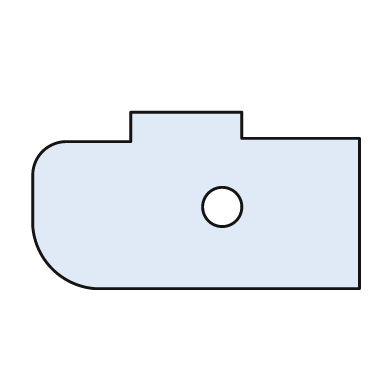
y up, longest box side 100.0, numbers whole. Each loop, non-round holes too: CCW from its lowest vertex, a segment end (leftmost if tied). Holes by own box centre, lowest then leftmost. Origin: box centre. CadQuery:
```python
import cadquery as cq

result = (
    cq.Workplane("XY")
    .moveTo(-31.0, -27.0)
    .lineTo(50.0, -27.0)
    .lineTo(50.0, 19.0)
    .lineTo(14.0, 19.0)
    .lineTo(14.0, 27.0)
    .lineTo(-20.0, 27.0)
    .lineTo(-20.0, 18.0)
    .lineTo(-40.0, 18.0)
    .threePointArc((-47.0, 15.0), (-50.0, 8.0))
    .lineTo(-50.0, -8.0)
    .threePointArc((-44.0, -21.0), (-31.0, -27.0))
    .close()
    .moveTo(8.0, -2.0)
    .circle(6.0)
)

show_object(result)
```